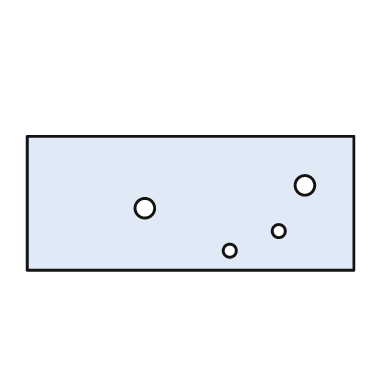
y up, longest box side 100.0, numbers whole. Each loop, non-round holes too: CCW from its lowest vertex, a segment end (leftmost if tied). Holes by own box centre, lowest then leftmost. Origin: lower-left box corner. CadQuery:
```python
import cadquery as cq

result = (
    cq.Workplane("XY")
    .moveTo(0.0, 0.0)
    .lineTo(100.0, 0.0)
    .lineTo(100.0, 41.0)
    .lineTo(0.0, 41.0)
    .close()
    .moveTo(62.0, 6.0)
    .circle(2.0)
    .moveTo(77.0, 12.0)
    .circle(2.0)
    .moveTo(36.0, 19.0)
    .circle(3.0)
    .moveTo(85.0, 26.0)
    .circle(3.0)
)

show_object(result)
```